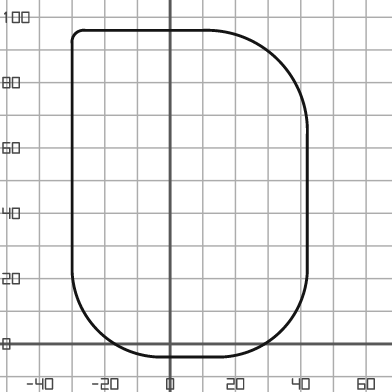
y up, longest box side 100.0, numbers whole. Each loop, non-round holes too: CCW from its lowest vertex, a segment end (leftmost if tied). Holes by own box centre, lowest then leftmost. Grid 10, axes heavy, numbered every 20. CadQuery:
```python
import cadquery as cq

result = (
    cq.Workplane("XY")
    .moveTo(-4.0, -4.0)
    .lineTo(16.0, -4.0)
    .threePointArc((34.0, 4.0), (42.0, 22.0))
    .lineTo(42.0, 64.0)
    .threePointArc((33.0, 87.0), (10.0, 96.0))
    .lineTo(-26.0, 96.0)
    .threePointArc((-29.0, 95.0), (-30.0, 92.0))
    .lineTo(-30.0, 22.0)
    .threePointArc((-22.0, 4.0), (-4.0, -4.0))
    .close()
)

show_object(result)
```